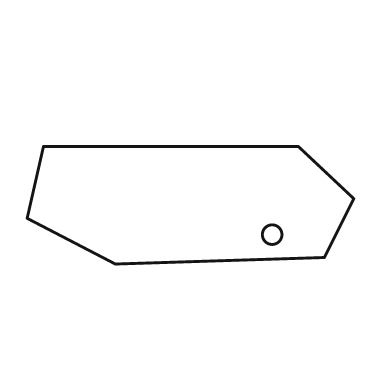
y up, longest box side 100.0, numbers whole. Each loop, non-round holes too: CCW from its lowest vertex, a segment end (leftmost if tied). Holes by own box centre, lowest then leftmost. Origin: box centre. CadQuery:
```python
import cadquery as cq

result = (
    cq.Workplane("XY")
    .moveTo(-23.0, -18.0)
    .lineTo(41.0, -16.0)
    .lineTo(50.0, 2.0)
    .lineTo(33.0, 18.0)
    .lineTo(-45.0, 18.0)
    .lineTo(-50.0, -4.0)
    .close()
    .moveTo(25.0, -9.0)
    .circle(3.0)
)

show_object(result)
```